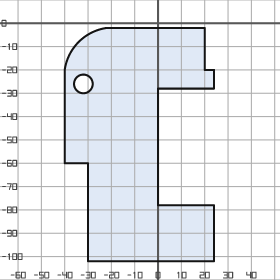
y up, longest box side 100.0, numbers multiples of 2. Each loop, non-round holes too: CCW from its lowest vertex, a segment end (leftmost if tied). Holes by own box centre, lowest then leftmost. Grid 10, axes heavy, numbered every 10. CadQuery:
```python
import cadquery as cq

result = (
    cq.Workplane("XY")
    .moveTo(-30.0, -102.0)
    .lineTo(24.0, -102.0)
    .lineTo(24.0, -78.0)
    .lineTo(0.0, -78.0)
    .lineTo(0.0, -28.0)
    .lineTo(24.0, -28.0)
    .lineTo(24.0, -20.0)
    .lineTo(20.0, -20.0)
    .lineTo(20.0, -2.0)
    .lineTo(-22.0, -2.0)
    .threePointArc((-34.0, -8.0), (-40.0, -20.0))
    .lineTo(-40.0, -60.0)
    .lineTo(-30.0, -60.0)
    .close()
    .moveTo(-32.0, -26.0)
    .circle(4.0)
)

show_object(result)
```